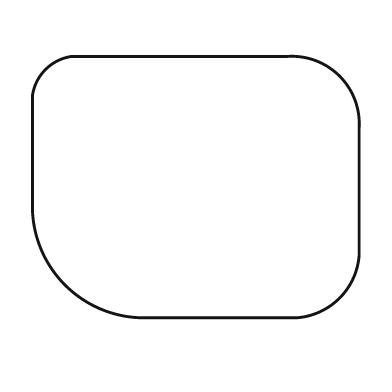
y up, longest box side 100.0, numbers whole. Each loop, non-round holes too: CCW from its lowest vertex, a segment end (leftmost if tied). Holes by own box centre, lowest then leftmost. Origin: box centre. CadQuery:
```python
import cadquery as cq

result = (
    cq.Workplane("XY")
    .moveTo(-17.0, -40.0)
    .lineTo(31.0, -40.0)
    .threePointArc((44.0, -34.0), (50.0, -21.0))
    .lineTo(50.0, 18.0)
    .threePointArc((44.0, 34.0), (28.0, 40.0))
    .lineTo(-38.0, 40.0)
    .threePointArc((-46.0, 36.0), (-50.0, 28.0))
    .lineTo(-50.0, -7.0)
    .threePointArc((-40.0, -30.0), (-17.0, -40.0))
    .close()
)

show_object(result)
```